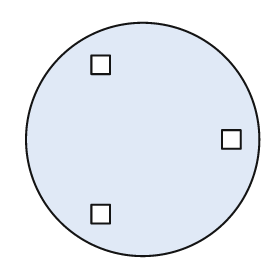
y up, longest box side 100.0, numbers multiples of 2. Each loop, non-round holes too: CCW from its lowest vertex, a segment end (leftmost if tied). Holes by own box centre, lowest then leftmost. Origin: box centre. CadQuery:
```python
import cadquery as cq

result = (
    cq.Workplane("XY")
    .moveTo(0.0, 0.0)
    .circle(50.0)
    .moveTo(-22.0, -36.0)
    .lineTo(-14.0, -36.0)
    .lineTo(-14.0, -28.0)
    .lineTo(-22.0, -28.0)
    .close()
    .moveTo(34.0, -4.0)
    .lineTo(42.0, -4.0)
    .lineTo(42.0, 4.0)
    .lineTo(34.0, 4.0)
    .close()
    .moveTo(-22.0, 28.0)
    .lineTo(-14.0, 28.0)
    .lineTo(-14.0, 36.0)
    .lineTo(-22.0, 36.0)
    .close()
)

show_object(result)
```